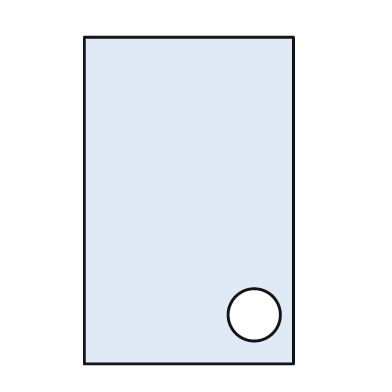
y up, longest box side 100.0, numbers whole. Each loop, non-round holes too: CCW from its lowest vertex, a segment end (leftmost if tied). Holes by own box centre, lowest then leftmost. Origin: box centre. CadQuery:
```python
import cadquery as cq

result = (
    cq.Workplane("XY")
    .moveTo(-32.0, -50.0)
    .lineTo(32.0, -50.0)
    .lineTo(32.0, 50.0)
    .lineTo(-32.0, 50.0)
    .close()
    .moveTo(20.0, -35.0)
    .circle(8.0)
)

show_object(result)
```